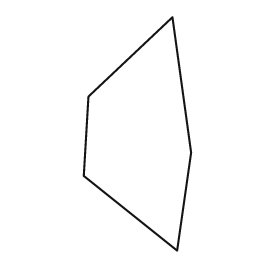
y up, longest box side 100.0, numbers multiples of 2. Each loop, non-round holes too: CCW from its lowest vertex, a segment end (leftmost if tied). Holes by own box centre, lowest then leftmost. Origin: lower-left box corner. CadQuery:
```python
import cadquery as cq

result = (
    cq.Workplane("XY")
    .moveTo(40.0, 0.0)
    .lineTo(46.0, 42.0)
    .lineTo(38.0, 100.0)
    .lineTo(2.0, 66.0)
    .lineTo(0.0, 32.0)
    .close()
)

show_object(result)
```